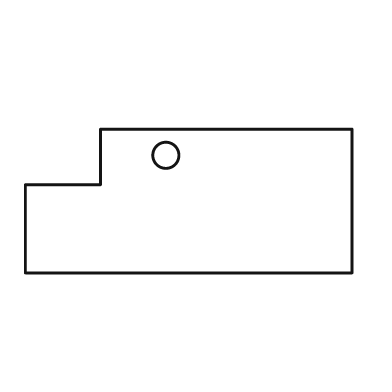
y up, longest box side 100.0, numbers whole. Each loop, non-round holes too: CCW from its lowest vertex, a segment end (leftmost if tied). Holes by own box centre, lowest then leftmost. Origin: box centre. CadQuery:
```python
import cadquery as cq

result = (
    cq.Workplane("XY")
    .moveTo(-50.0, -22.0)
    .lineTo(50.0, -22.0)
    .lineTo(50.0, 22.0)
    .lineTo(-27.0, 22.0)
    .lineTo(-27.0, 5.0)
    .lineTo(-50.0, 5.0)
    .close()
    .moveTo(-7.0, 14.0)
    .circle(4.0)
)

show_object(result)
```